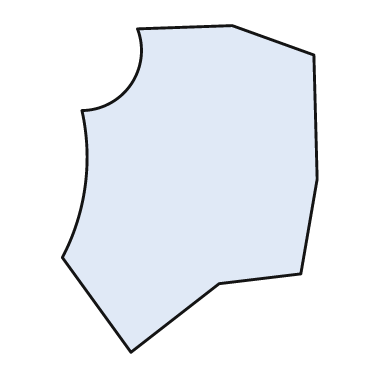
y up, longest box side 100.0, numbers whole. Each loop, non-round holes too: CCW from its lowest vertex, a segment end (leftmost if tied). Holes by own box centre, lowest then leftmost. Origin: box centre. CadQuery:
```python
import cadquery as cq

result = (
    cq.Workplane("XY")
    .moveTo(-18.0, -50.0)
    .lineTo(9.0, -29.0)
    .lineTo(34.0, -26.0)
    .lineTo(39.0, 3.0)
    .lineTo(38.0, 41.0)
    .lineTo(13.0, 50.0)
    .lineTo(-16.0, 49.0)
    .threePointArc((-18.0, 32.0), (-33.0, 24.0))
    .threePointArc((-32.0, 1.0), (-39.0, -21.0))
    .close()
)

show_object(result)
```